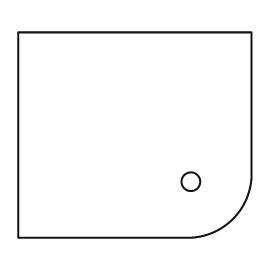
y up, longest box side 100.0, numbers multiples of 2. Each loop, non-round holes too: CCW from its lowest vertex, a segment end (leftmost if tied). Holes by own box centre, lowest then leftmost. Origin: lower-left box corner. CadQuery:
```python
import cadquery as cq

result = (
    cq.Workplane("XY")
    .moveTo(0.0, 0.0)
    .lineTo(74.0, 0.0)
    .threePointArc((92.0, 8.0), (100.0, 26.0))
    .lineTo(100.0, 88.0)
    .lineTo(0.0, 88.0)
    .close()
    .moveTo(74.0, 24.0)
    .circle(4.0)
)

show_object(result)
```